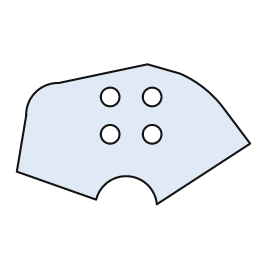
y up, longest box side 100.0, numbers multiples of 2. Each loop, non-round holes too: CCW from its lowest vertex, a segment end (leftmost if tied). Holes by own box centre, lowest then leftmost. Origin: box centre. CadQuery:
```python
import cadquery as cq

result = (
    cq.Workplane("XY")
    .moveTo(10.0, -30.0)
    .lineTo(50.0, -4.0)
    .lineTo(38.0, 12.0)
    .threePointArc((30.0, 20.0), (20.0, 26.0))
    .lineTo(6.0, 30.0)
    .lineTo(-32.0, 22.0)
    .threePointArc((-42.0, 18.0), (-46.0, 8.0))
    .lineTo(-50.0, -16.0)
    .lineTo(-16.0, -28.0)
    .threePointArc((-2.0, -18.0), (10.0, -30.0))
    .close()
    .moveTo(-10.0, 0.0)
    .circle(4.0)
    .moveTo(8.0, 0.0)
    .circle(4.0)
    .moveTo(-10.0, 16.0)
    .circle(4.0)
    .moveTo(8.0, 16.0)
    .circle(4.0)
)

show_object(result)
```